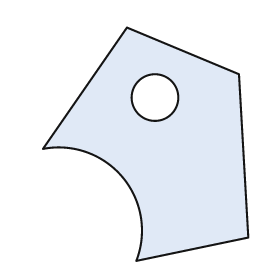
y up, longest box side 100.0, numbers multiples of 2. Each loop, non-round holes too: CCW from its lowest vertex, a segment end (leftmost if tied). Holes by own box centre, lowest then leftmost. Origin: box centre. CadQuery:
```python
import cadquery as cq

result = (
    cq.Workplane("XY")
    .moveTo(-4.0, -50.0)
    .lineTo(44.0, -40.0)
    .lineTo(40.0, 30.0)
    .lineTo(-8.0, 50.0)
    .lineTo(-44.0, -2.0)
    .threePointArc((-10.0, -14.0), (-4.0, -50.0))
    .close()
    .moveTo(4.0, 20.0)
    .circle(10.0)
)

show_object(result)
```